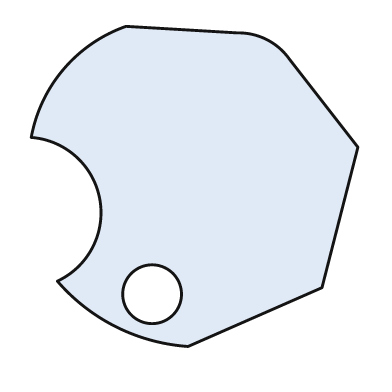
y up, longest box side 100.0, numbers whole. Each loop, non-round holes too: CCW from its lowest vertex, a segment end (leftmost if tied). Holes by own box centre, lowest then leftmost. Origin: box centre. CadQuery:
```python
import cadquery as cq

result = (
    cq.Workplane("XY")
    .moveTo(-2.0, -49.0)
    .lineTo(39.0, -31.0)
    .lineTo(50.0, 12.0)
    .lineTo(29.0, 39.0)
    .threePointArc((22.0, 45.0), (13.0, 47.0))
    .lineTo(-21.0, 49.0)
    .threePointArc((-40.0, 36.0), (-50.0, 15.0))
    .threePointArc((-29.0, -4.0), (-42.0, -29.0))
    .threePointArc((-24.0, -43.0), (-2.0, -49.0))
    .close()
    .moveTo(-13.0, -33.0)
    .circle(9.0)
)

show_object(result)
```